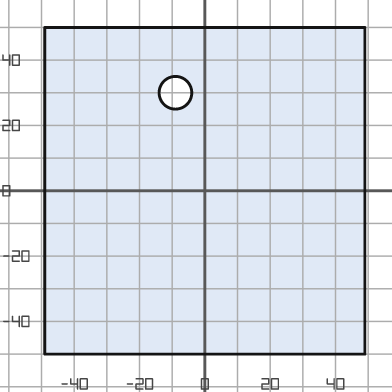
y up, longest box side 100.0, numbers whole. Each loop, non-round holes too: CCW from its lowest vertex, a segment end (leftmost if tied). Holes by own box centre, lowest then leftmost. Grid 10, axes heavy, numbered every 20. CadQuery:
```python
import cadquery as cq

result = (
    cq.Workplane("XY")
    .moveTo(-49.0, -50.0)
    .lineTo(49.0, -50.0)
    .lineTo(49.0, 50.0)
    .lineTo(-49.0, 50.0)
    .close()
    .moveTo(-9.0, 30.0)
    .circle(5.0)
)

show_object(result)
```